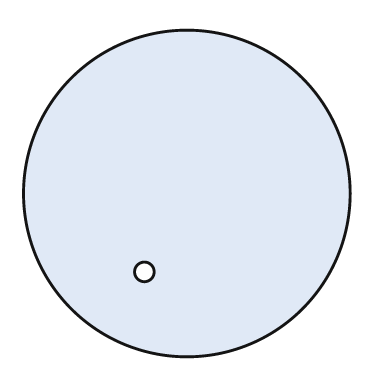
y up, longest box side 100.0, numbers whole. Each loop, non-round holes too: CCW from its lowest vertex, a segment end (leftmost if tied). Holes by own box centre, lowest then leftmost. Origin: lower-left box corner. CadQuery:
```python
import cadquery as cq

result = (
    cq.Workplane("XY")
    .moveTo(50.0, 50.0)
    .circle(50.0)
    .moveTo(37.0, 26.0)
    .circle(3.0)
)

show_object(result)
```